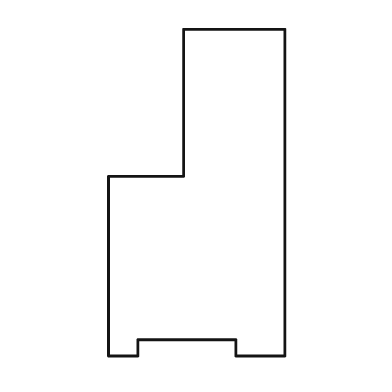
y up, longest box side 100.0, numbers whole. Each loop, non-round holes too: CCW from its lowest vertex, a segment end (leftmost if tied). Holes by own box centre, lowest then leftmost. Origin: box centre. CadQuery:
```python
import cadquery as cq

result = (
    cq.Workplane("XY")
    .moveTo(-27.0, -50.0)
    .lineTo(-18.0, -50.0)
    .lineTo(-18.0, -45.0)
    .lineTo(12.0, -45.0)
    .lineTo(12.0, -50.0)
    .lineTo(27.0, -50.0)
    .lineTo(27.0, 50.0)
    .lineTo(-4.0, 50.0)
    .lineTo(-4.0, 5.0)
    .lineTo(-27.0, 5.0)
    .close()
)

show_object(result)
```